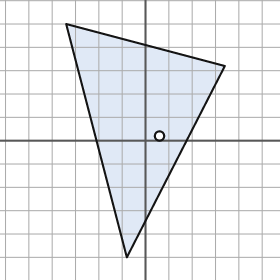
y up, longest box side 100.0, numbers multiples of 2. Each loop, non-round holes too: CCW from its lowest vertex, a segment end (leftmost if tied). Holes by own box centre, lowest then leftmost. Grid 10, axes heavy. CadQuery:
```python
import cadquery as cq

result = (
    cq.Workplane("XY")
    .moveTo(-8.0, -50.0)
    .lineTo(34.0, 32.0)
    .lineTo(-34.0, 50.0)
    .close()
    .moveTo(6.0, 2.0)
    .circle(2.0)
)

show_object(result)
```